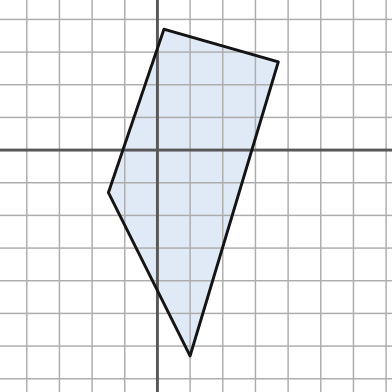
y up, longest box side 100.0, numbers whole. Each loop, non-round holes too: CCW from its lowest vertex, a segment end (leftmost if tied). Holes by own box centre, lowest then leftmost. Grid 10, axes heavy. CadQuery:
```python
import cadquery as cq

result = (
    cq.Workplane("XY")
    .moveTo(10.0, -63.0)
    .lineTo(37.0, 27.0)
    .lineTo(2.0, 37.0)
    .lineTo(-15.0, -13.0)
    .close()
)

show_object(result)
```